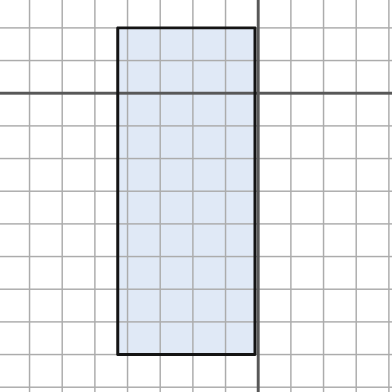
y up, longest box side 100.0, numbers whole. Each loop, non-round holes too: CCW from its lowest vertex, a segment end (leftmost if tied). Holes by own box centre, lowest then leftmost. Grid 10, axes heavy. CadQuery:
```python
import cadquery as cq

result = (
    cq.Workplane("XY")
    .moveTo(-43.0, -80.0)
    .lineTo(-1.0, -80.0)
    .lineTo(-1.0, 20.0)
    .lineTo(-43.0, 20.0)
    .close()
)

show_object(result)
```